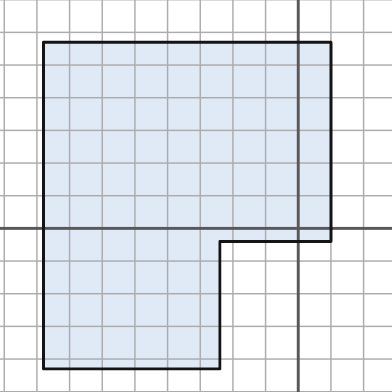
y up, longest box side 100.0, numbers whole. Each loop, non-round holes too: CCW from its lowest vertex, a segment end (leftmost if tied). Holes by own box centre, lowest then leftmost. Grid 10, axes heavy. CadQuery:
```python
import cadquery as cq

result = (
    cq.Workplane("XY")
    .moveTo(-78.0, -43.0)
    .lineTo(-24.0, -43.0)
    .lineTo(-24.0, -4.0)
    .lineTo(10.0, -4.0)
    .lineTo(10.0, 57.0)
    .lineTo(-78.0, 57.0)
    .close()
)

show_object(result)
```